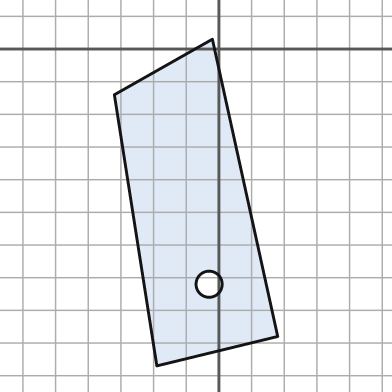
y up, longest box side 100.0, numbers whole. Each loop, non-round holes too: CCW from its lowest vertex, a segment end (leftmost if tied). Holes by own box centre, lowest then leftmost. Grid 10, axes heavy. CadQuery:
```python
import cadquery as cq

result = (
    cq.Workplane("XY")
    .moveTo(-19.0, -97.0)
    .lineTo(18.0, -88.0)
    .lineTo(-2.0, 3.0)
    .lineTo(-32.0, -14.0)
    .close()
    .moveTo(-3.0, -72.0)
    .circle(4.0)
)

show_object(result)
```